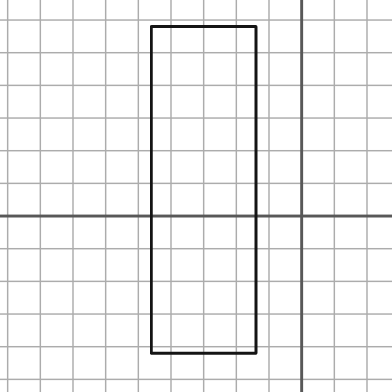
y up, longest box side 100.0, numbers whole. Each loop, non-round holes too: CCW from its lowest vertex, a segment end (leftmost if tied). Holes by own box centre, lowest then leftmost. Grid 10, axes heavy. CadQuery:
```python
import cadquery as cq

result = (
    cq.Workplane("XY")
    .moveTo(-46.0, -42.0)
    .lineTo(-14.0, -42.0)
    .lineTo(-14.0, 58.0)
    .lineTo(-46.0, 58.0)
    .close()
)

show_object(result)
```